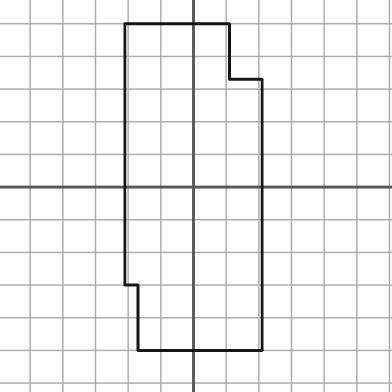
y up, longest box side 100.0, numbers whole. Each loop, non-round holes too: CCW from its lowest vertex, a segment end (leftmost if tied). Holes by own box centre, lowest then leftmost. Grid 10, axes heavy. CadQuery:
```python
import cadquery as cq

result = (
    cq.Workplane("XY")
    .moveTo(-17.0, -50.0)
    .lineTo(21.0, -50.0)
    .lineTo(21.0, 33.0)
    .lineTo(11.0, 33.0)
    .lineTo(11.0, 50.0)
    .lineTo(-21.0, 50.0)
    .lineTo(-21.0, -30.0)
    .lineTo(-17.0, -30.0)
    .close()
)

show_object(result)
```